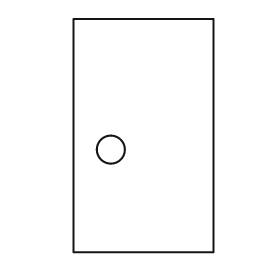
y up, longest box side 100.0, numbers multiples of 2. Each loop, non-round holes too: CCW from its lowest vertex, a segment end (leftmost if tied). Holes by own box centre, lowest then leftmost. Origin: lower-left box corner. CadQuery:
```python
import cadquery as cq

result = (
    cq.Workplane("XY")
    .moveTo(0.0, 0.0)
    .lineTo(60.0, 0.0)
    .lineTo(60.0, 100.0)
    .lineTo(0.0, 100.0)
    .close()
    .moveTo(16.0, 44.0)
    .circle(6.0)
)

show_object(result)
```